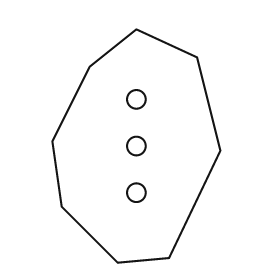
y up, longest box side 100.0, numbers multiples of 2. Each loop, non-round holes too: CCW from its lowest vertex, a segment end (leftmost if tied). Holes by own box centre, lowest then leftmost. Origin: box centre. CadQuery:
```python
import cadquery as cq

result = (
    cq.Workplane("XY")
    .moveTo(-8.0, -50.0)
    .lineTo(14.0, -48.0)
    .lineTo(36.0, -2.0)
    .lineTo(26.0, 38.0)
    .lineTo(0.0, 50.0)
    .lineTo(-20.0, 34.0)
    .lineTo(-36.0, 2.0)
    .lineTo(-32.0, -26.0)
    .close()
    .moveTo(0.0, -20.0)
    .circle(4.0)
    .moveTo(0.0, 0.0)
    .circle(4.0)
    .moveTo(0.0, 20.0)
    .circle(4.0)
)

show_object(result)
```